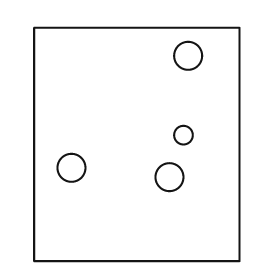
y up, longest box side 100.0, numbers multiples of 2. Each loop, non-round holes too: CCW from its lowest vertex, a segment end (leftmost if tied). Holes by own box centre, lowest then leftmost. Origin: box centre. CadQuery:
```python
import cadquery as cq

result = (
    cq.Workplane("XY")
    .moveTo(-44.0, -50.0)
    .lineTo(44.0, -50.0)
    .lineTo(44.0, 50.0)
    .lineTo(-44.0, 50.0)
    .close()
    .moveTo(14.0, -14.0)
    .circle(6.0)
    .moveTo(-28.0, -10.0)
    .circle(6.0)
    .moveTo(20.0, 4.0)
    .circle(4.0)
    .moveTo(22.0, 38.0)
    .circle(6.0)
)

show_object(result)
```